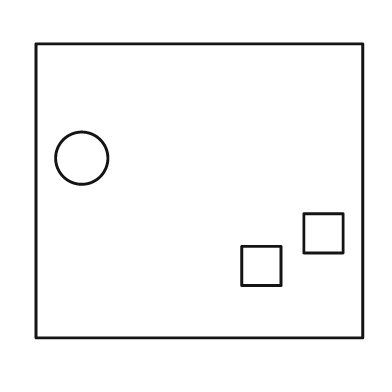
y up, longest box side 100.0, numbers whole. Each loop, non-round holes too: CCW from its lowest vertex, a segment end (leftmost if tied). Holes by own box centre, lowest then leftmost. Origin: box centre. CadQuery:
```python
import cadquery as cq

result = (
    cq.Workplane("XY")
    .moveTo(-50.0, -45.0)
    .lineTo(50.0, -45.0)
    .lineTo(50.0, 45.0)
    .lineTo(-50.0, 45.0)
    .close()
    .moveTo(13.0, -29.0)
    .lineTo(25.0, -29.0)
    .lineTo(25.0, -17.0)
    .lineTo(13.0, -17.0)
    .close()
    .moveTo(32.0, -19.0)
    .lineTo(44.0, -19.0)
    .lineTo(44.0, -7.0)
    .lineTo(32.0, -7.0)
    .close()
    .moveTo(-36.0, 10.0)
    .circle(8.0)
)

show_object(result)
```